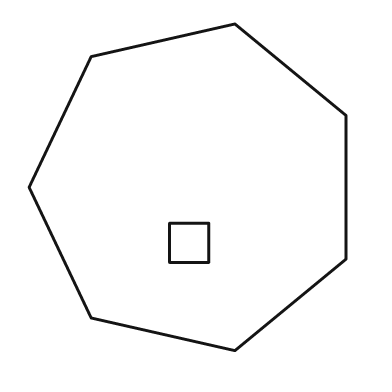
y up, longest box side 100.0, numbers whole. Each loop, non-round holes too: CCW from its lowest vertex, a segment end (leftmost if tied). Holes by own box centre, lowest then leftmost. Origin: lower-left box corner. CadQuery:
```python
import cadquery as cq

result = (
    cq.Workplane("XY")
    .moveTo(63.0, 0.0)
    .lineTo(97.0, 28.0)
    .lineTo(97.0, 72.0)
    .lineTo(63.0, 100.0)
    .lineTo(19.0, 90.0)
    .lineTo(0.0, 50.0)
    .lineTo(19.0, 10.0)
    .close()
    .moveTo(43.0, 27.0)
    .lineTo(55.0, 27.0)
    .lineTo(55.0, 39.0)
    .lineTo(43.0, 39.0)
    .close()
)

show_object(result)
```